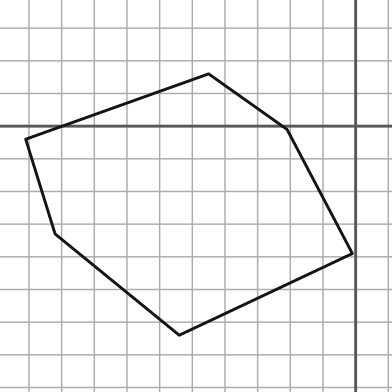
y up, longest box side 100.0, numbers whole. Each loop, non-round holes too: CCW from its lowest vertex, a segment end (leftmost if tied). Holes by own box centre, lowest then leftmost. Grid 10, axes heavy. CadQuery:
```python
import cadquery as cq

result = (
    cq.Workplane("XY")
    .moveTo(-54.0, -64.0)
    .lineTo(-1.0, -39.0)
    .lineTo(-21.0, -1.0)
    .lineTo(-45.0, 16.0)
    .lineTo(-101.0, -4.0)
    .lineTo(-92.0, -33.0)
    .close()
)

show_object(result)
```